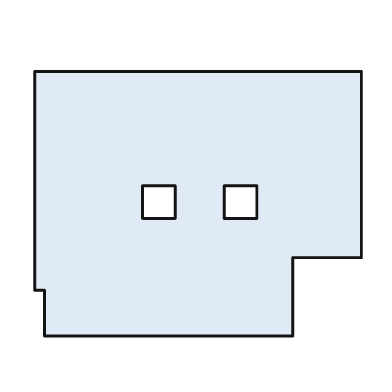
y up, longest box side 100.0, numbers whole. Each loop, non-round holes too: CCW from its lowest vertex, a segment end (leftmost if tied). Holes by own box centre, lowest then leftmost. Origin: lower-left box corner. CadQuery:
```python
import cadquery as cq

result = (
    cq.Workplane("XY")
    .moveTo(3.0, 0.0)
    .lineTo(79.0, 0.0)
    .lineTo(79.0, 24.0)
    .lineTo(100.0, 24.0)
    .lineTo(100.0, 81.0)
    .lineTo(0.0, 81.0)
    .lineTo(0.0, 14.0)
    .lineTo(3.0, 14.0)
    .close()
    .moveTo(33.0, 36.0)
    .lineTo(43.0, 36.0)
    .lineTo(43.0, 46.0)
    .lineTo(33.0, 46.0)
    .close()
    .moveTo(58.0, 36.0)
    .lineTo(68.0, 36.0)
    .lineTo(68.0, 46.0)
    .lineTo(58.0, 46.0)
    .close()
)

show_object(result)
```